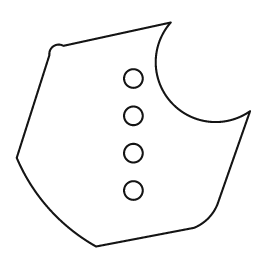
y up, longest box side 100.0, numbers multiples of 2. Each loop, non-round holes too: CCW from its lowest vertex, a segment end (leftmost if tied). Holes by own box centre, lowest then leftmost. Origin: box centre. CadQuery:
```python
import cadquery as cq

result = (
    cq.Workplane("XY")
    .moveTo(-16.0, -48.0)
    .lineTo(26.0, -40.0)
    .threePointArc((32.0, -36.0), (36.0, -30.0))
    .lineTo(50.0, 10.0)
    .threePointArc((16.0, 14.0), (16.0, 48.0))
    .lineTo(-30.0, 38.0)
    .threePointArc((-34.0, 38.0), (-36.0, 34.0))
    .lineTo(-50.0, -10.0)
    .threePointArc((-36.0, -32.0), (-16.0, -48.0))
    .close()
    .moveTo(0.0, -24.0)
    .circle(4.0)
    .moveTo(0.0, -8.0)
    .circle(4.0)
    .moveTo(0.0, 8.0)
    .circle(4.0)
    .moveTo(0.0, 24.0)
    .circle(4.0)
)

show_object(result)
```